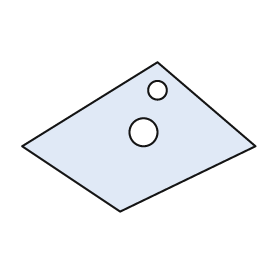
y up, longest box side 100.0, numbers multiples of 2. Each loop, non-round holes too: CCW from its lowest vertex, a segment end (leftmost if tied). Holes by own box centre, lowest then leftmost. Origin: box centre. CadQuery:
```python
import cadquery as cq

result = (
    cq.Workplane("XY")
    .moveTo(-8.0, -32.0)
    .lineTo(50.0, -4.0)
    .lineTo(8.0, 32.0)
    .lineTo(-50.0, -4.0)
    .close()
    .moveTo(2.0, 2.0)
    .circle(6.0)
    .moveTo(8.0, 20.0)
    .circle(4.0)
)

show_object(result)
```